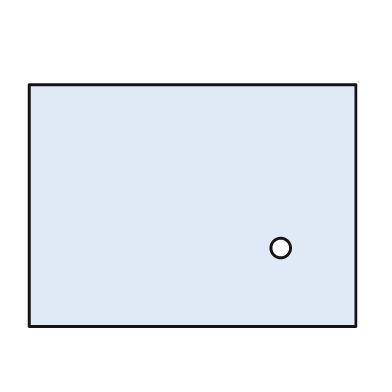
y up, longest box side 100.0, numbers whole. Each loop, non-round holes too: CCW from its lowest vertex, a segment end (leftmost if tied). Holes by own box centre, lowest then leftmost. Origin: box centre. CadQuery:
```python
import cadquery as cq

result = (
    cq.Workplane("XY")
    .moveTo(-50.0, -37.0)
    .lineTo(50.0, -37.0)
    .lineTo(50.0, 37.0)
    .lineTo(-50.0, 37.0)
    .close()
    .moveTo(27.0, -13.0)
    .circle(3.0)
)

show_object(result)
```